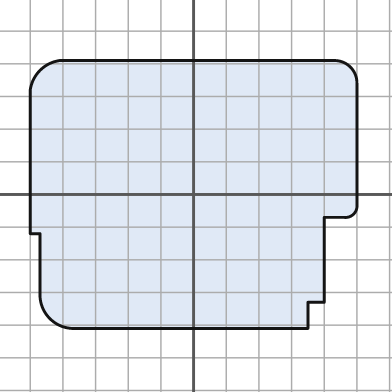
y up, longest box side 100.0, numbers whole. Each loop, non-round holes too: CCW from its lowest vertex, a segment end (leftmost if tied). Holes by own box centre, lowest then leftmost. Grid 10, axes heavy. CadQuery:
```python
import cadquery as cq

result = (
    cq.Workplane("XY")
    .moveTo(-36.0, -41.0)
    .lineTo(35.0, -41.0)
    .lineTo(35.0, -33.0)
    .lineTo(40.0, -33.0)
    .lineTo(40.0, -7.0)
    .lineTo(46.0, -7.0)
    .threePointArc((49.0, -6.0), (50.0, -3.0))
    .lineTo(50.0, 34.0)
    .threePointArc((48.0, 39.0), (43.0, 41.0))
    .lineTo(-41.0, 41.0)
    .threePointArc((-47.0, 38.0), (-50.0, 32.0))
    .lineTo(-50.0, -12.0)
    .lineTo(-47.0, -12.0)
    .lineTo(-47.0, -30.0)
    .threePointArc((-44.0, -38.0), (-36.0, -41.0))
    .close()
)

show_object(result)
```